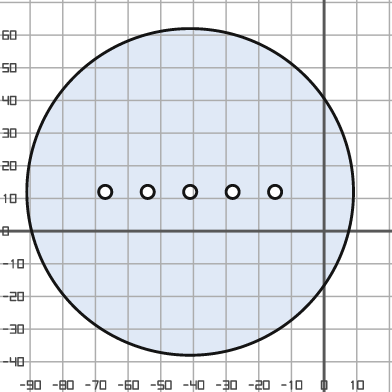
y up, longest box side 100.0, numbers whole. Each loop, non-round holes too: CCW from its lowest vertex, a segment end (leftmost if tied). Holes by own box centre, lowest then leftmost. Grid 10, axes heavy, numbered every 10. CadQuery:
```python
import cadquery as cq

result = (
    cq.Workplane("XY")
    .moveTo(-41.0, 12.0)
    .circle(50.0)
    .moveTo(-67.0, 12.0)
    .circle(2.0)
    .moveTo(-54.0, 12.0)
    .circle(2.0)
    .moveTo(-41.0, 12.0)
    .circle(2.0)
    .moveTo(-28.0, 12.0)
    .circle(2.0)
    .moveTo(-15.0, 12.0)
    .circle(2.0)
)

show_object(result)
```